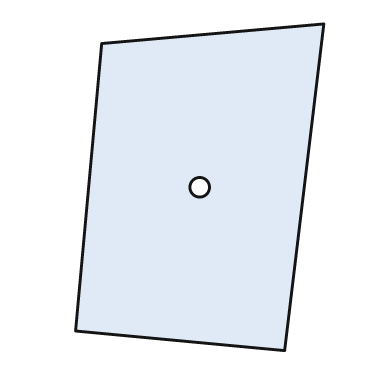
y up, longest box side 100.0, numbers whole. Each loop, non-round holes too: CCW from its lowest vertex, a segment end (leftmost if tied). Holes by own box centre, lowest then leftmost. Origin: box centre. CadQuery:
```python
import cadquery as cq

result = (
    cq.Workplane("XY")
    .moveTo(26.0, -50.0)
    .lineTo(38.0, 50.0)
    .lineTo(-30.0, 44.0)
    .lineTo(-38.0, -44.0)
    .close()
    .moveTo(0.0, 0.0)
    .circle(3.0)
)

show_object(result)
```